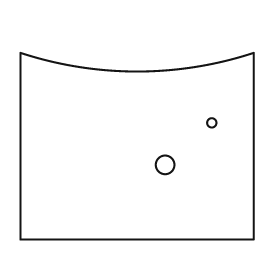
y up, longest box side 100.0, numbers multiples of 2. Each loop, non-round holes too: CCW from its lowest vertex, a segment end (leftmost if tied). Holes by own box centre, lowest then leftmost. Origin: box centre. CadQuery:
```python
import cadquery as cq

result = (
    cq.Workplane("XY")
    .moveTo(-50.0, -40.0)
    .lineTo(50.0, -40.0)
    .lineTo(50.0, 40.0)
    .threePointArc((0.0, 32.0), (-50.0, 40.0))
    .close()
    .moveTo(12.0, -8.0)
    .circle(4.0)
    .moveTo(32.0, 10.0)
    .circle(2.0)
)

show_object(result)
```